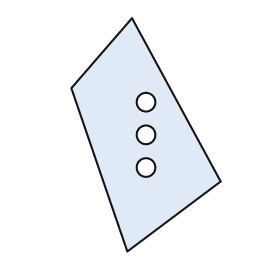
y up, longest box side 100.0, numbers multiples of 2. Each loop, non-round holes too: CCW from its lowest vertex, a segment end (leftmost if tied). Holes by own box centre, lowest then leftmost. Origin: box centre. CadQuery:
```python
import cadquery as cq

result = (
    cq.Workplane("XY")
    .moveTo(-8.0, -50.0)
    .lineTo(32.0, -20.0)
    .lineTo(-6.0, 50.0)
    .lineTo(-32.0, 20.0)
    .close()
    .moveTo(0.0, -14.0)
    .circle(4.0)
    .moveTo(0.0, 0.0)
    .circle(4.0)
    .moveTo(0.0, 14.0)
    .circle(4.0)
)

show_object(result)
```